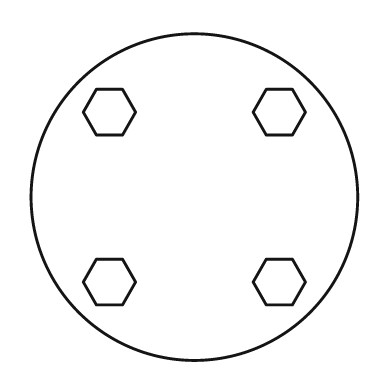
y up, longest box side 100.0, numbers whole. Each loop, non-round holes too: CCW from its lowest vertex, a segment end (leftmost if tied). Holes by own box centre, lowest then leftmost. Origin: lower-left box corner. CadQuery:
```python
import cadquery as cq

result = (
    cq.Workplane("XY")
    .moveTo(50.0, 50.0)
    .circle(50.0)
    .moveTo(20.0, 17.0)
    .lineTo(28.0, 17.0)
    .lineTo(32.0, 24.0)
    .lineTo(28.0, 31.0)
    .lineTo(20.0, 31.0)
    .lineTo(16.0, 24.0)
    .close()
    .moveTo(72.0, 17.0)
    .lineTo(80.0, 17.0)
    .lineTo(84.0, 24.0)
    .lineTo(80.0, 31.0)
    .lineTo(72.0, 31.0)
    .lineTo(68.0, 24.0)
    .close()
    .moveTo(20.0, 69.0)
    .lineTo(28.0, 69.0)
    .lineTo(32.0, 76.0)
    .lineTo(28.0, 83.0)
    .lineTo(20.0, 83.0)
    .lineTo(16.0, 76.0)
    .close()
    .moveTo(72.0, 69.0)
    .lineTo(80.0, 69.0)
    .lineTo(84.0, 76.0)
    .lineTo(80.0, 83.0)
    .lineTo(72.0, 83.0)
    .lineTo(68.0, 76.0)
    .close()
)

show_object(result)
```